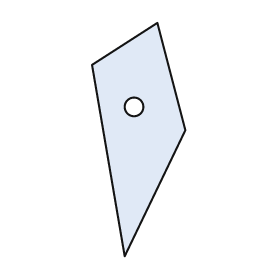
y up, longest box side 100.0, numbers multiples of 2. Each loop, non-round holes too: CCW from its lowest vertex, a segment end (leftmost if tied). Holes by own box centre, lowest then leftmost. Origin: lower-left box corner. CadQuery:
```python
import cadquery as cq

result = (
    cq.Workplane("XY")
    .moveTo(14.0, 0.0)
    .lineTo(40.0, 54.0)
    .lineTo(28.0, 100.0)
    .lineTo(0.0, 82.0)
    .close()
    .moveTo(18.0, 64.0)
    .circle(4.0)
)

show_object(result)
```